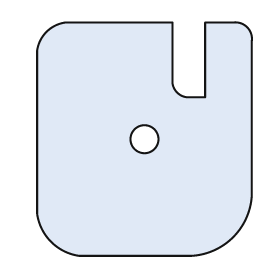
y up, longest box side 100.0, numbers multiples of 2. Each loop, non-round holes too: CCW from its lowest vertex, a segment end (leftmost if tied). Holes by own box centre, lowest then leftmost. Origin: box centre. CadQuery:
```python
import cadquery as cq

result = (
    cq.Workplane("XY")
    .moveTo(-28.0, -50.0)
    .lineTo(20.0, -50.0)
    .threePointArc((38.0, -42.0), (46.0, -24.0))
    .lineTo(46.0, 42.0)
    .threePointArc((44.0, 48.0), (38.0, 50.0))
    .lineTo(26.0, 50.0)
    .lineTo(26.0, 18.0)
    .lineTo(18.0, 18.0)
    .threePointArc((14.0, 20.0), (12.0, 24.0))
    .lineTo(12.0, 50.0)
    .lineTo(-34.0, 50.0)
    .threePointArc((-42.0, 46.0), (-46.0, 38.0))
    .lineTo(-46.0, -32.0)
    .threePointArc((-40.0, -44.0), (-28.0, -50.0))
    .close()
    .moveTo(0.0, 0.0)
    .circle(6.0)
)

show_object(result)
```